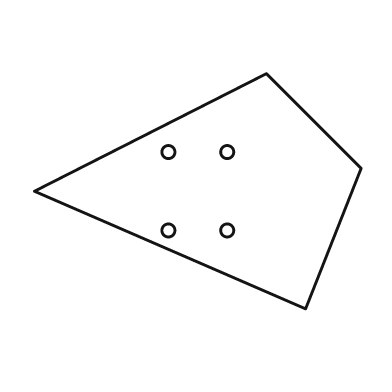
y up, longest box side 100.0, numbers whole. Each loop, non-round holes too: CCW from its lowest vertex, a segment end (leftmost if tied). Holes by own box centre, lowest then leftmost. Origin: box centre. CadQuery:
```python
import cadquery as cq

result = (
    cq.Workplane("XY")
    .moveTo(33.0, -36.0)
    .lineTo(50.0, 7.0)
    .lineTo(21.0, 36.0)
    .lineTo(-50.0, 0.0)
    .close()
    .moveTo(-9.0, -12.0)
    .circle(2.0)
    .moveTo(9.0, -12.0)
    .circle(2.0)
    .moveTo(-9.0, 12.0)
    .circle(2.0)
    .moveTo(9.0, 12.0)
    .circle(2.0)
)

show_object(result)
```